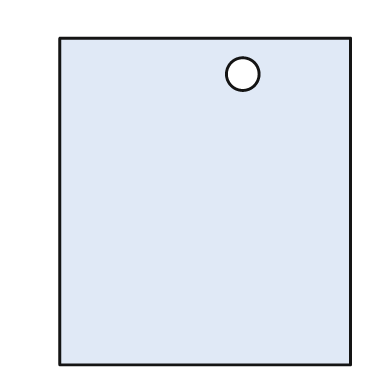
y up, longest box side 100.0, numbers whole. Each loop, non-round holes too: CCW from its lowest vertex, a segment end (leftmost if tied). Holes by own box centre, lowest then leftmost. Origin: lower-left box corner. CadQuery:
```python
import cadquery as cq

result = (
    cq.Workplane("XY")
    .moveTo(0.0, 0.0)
    .lineTo(89.0, 0.0)
    .lineTo(89.0, 100.0)
    .lineTo(0.0, 100.0)
    .close()
    .moveTo(56.0, 89.0)
    .circle(5.0)
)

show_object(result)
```